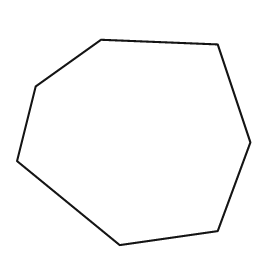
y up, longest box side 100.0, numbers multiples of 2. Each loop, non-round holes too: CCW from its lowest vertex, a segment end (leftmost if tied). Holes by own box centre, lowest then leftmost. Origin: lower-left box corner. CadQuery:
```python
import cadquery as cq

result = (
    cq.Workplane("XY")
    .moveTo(44.0, 0.0)
    .lineTo(86.0, 6.0)
    .lineTo(100.0, 44.0)
    .lineTo(86.0, 86.0)
    .lineTo(36.0, 88.0)
    .lineTo(8.0, 68.0)
    .lineTo(0.0, 36.0)
    .close()
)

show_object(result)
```